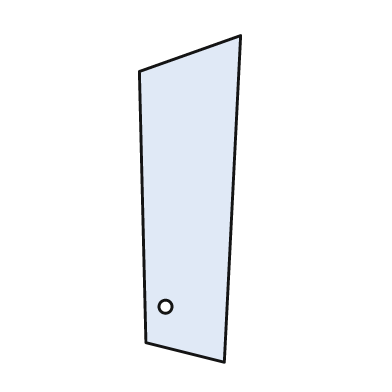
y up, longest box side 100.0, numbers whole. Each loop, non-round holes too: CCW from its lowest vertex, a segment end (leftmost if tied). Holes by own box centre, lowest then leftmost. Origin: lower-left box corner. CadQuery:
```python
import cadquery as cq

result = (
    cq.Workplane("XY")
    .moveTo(26.0, 0.0)
    .lineTo(31.0, 100.0)
    .lineTo(0.0, 89.0)
    .lineTo(2.0, 6.0)
    .close()
    .moveTo(8.0, 17.0)
    .circle(2.0)
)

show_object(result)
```